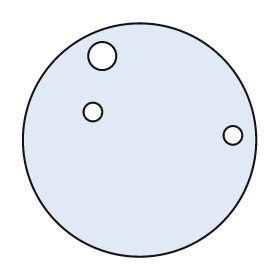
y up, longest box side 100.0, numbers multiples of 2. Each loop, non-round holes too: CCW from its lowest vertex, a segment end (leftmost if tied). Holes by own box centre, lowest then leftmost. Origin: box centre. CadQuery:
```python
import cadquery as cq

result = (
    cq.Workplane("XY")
    .moveTo(0.0, 0.0)
    .circle(50.0)
    .moveTo(40.0, 2.0)
    .circle(4.0)
    .moveTo(-20.0, 12.0)
    .circle(4.0)
    .moveTo(-16.0, 36.0)
    .circle(6.0)
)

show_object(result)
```